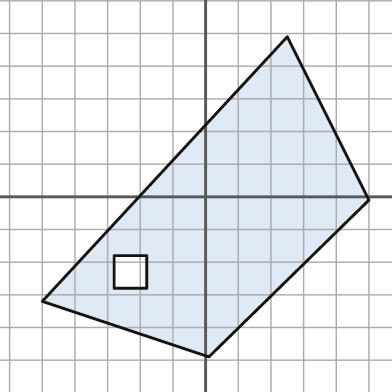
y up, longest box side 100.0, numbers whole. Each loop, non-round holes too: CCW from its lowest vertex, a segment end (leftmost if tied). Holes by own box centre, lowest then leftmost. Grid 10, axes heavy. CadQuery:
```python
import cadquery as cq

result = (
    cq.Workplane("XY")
    .moveTo(1.0, -49.0)
    .lineTo(50.0, -1.0)
    .lineTo(25.0, 49.0)
    .lineTo(-50.0, -32.0)
    .close()
    .moveTo(-28.0, -28.0)
    .lineTo(-18.0, -28.0)
    .lineTo(-18.0, -18.0)
    .lineTo(-28.0, -18.0)
    .close()
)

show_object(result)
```